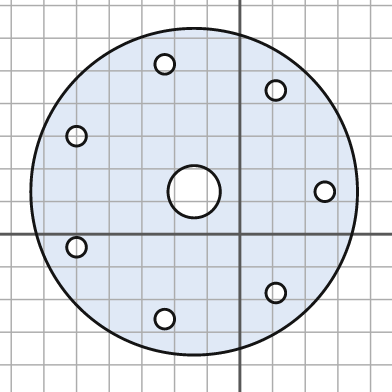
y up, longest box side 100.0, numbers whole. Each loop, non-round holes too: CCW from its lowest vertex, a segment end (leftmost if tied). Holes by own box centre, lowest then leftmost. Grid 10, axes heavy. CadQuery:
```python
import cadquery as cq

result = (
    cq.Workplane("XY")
    .moveTo(-14.0, 13.0)
    .circle(50.0)
    .moveTo(-23.0, -26.0)
    .circle(3.0)
    .moveTo(11.0, -18.0)
    .circle(3.0)
    .moveTo(-50.0, -4.0)
    .circle(3.0)
    .moveTo(-14.0, 13.0)
    .circle(8.0)
    .moveTo(26.0, 13.0)
    .circle(3.0)
    .moveTo(-50.0, 30.0)
    .circle(3.0)
    .moveTo(11.0, 44.0)
    .circle(3.0)
    .moveTo(-23.0, 52.0)
    .circle(3.0)
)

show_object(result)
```